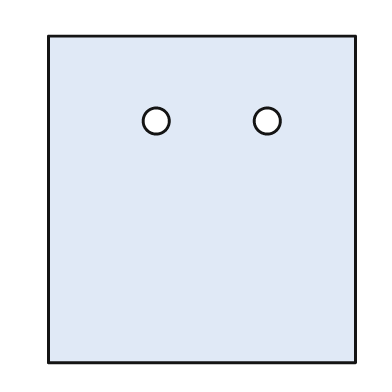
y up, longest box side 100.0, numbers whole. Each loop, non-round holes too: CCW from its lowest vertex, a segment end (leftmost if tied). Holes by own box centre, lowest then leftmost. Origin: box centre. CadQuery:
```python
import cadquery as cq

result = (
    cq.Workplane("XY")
    .moveTo(-47.0, -50.0)
    .lineTo(47.0, -50.0)
    .lineTo(47.0, 50.0)
    .lineTo(-47.0, 50.0)
    .close()
    .moveTo(-14.0, 24.0)
    .circle(4.0)
    .moveTo(20.0, 24.0)
    .circle(4.0)
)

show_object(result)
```